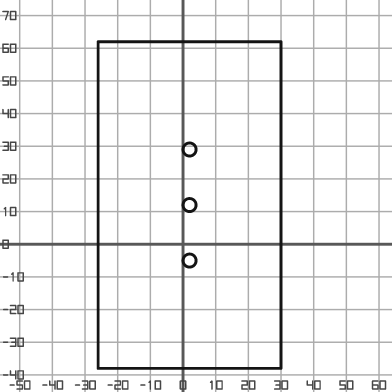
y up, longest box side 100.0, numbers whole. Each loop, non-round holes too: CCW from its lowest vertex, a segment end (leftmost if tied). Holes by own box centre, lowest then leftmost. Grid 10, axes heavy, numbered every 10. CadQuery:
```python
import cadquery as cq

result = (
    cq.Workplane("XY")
    .moveTo(-26.0, -38.0)
    .lineTo(30.0, -38.0)
    .lineTo(30.0, 62.0)
    .lineTo(-26.0, 62.0)
    .close()
    .moveTo(2.0, -5.0)
    .circle(2.0)
    .moveTo(2.0, 12.0)
    .circle(2.0)
    .moveTo(2.0, 29.0)
    .circle(2.0)
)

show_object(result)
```